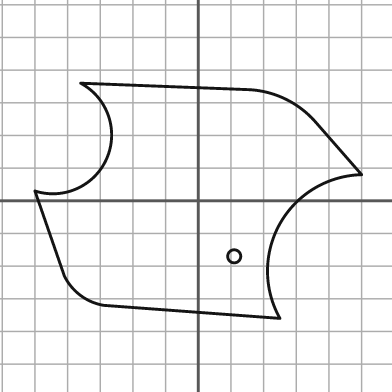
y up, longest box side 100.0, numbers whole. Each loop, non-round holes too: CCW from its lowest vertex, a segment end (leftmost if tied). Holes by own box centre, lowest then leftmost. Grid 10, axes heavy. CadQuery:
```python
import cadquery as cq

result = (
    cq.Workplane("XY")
    .moveTo(25.0, -36.0)
    .threePointArc((25.0, -7.0), (50.0, 8.0))
    .lineTo(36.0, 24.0)
    .threePointArc((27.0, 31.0), (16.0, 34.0))
    .lineTo(-36.0, 36.0)
    .threePointArc((-28.0, 13.0), (-50.0, 3.0))
    .lineTo(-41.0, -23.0)
    .threePointArc((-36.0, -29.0), (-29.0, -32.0))
    .close()
    .moveTo(11.0, -17.0)
    .circle(2.0)
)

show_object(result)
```